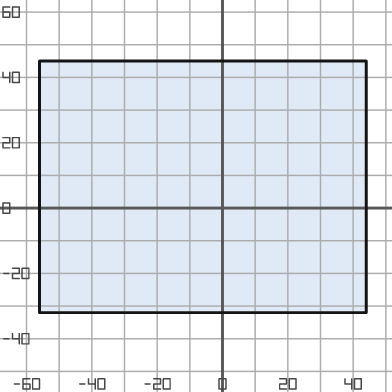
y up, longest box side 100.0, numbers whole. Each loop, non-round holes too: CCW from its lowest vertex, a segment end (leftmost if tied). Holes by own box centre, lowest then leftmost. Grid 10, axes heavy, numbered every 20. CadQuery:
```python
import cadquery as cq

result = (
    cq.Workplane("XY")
    .moveTo(-56.0, -32.0)
    .lineTo(44.0, -32.0)
    .lineTo(44.0, 45.0)
    .lineTo(-56.0, 45.0)
    .close()
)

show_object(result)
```